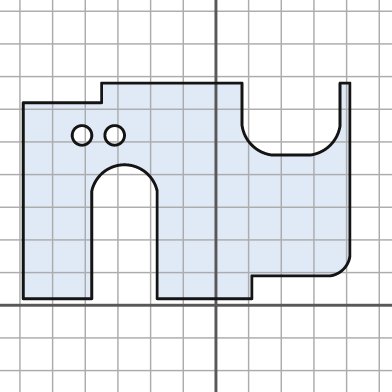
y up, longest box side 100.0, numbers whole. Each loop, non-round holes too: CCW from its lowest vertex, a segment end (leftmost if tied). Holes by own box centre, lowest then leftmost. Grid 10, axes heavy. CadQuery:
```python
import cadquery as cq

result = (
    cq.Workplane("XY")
    .moveTo(-59.0, 2.0)
    .lineTo(-38.0, 2.0)
    .lineTo(-38.0, 35.0)
    .threePointArc((-28.0, 43.0), (-18.0, 35.0))
    .lineTo(-18.0, 2.0)
    .lineTo(11.0, 2.0)
    .lineTo(11.0, 9.0)
    .lineTo(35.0, 9.0)
    .threePointArc((39.0, 11.0), (41.0, 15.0))
    .lineTo(41.0, 68.0)
    .lineTo(38.0, 68.0)
    .lineTo(38.0, 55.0)
    .threePointArc((35.0, 49.0), (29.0, 46.0))
    .lineTo(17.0, 46.0)
    .threePointArc((11.0, 49.0), (8.0, 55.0))
    .lineTo(8.0, 68.0)
    .lineTo(-35.0, 68.0)
    .lineTo(-35.0, 62.0)
    .lineTo(-59.0, 62.0)
    .close()
    .moveTo(-41.0, 52.0)
    .circle(3.0)
    .moveTo(-31.0, 52.0)
    .circle(3.0)
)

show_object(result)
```